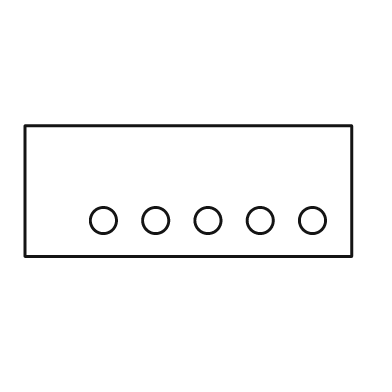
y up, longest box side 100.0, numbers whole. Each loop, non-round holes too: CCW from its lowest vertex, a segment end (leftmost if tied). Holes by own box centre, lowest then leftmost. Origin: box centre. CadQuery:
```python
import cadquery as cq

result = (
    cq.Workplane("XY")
    .moveTo(-50.0, -20.0)
    .lineTo(50.0, -20.0)
    .lineTo(50.0, 20.0)
    .lineTo(-50.0, 20.0)
    .close()
    .moveTo(-26.0, -9.0)
    .circle(4.0)
    .moveTo(-10.0, -9.0)
    .circle(4.0)
    .moveTo(6.0, -9.0)
    .circle(4.0)
    .moveTo(22.0, -9.0)
    .circle(4.0)
    .moveTo(38.0, -9.0)
    .circle(4.0)
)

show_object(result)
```